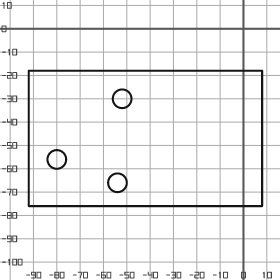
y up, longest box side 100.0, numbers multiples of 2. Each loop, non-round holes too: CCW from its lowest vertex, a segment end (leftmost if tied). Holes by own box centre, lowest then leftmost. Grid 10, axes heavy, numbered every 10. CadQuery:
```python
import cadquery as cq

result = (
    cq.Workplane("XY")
    .moveTo(-92.0, -76.0)
    .lineTo(8.0, -76.0)
    .lineTo(8.0, -18.0)
    .lineTo(-92.0, -18.0)
    .close()
    .moveTo(-54.0, -66.0)
    .circle(4.0)
    .moveTo(-80.0, -56.0)
    .circle(4.0)
    .moveTo(-52.0, -30.0)
    .circle(4.0)
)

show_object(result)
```